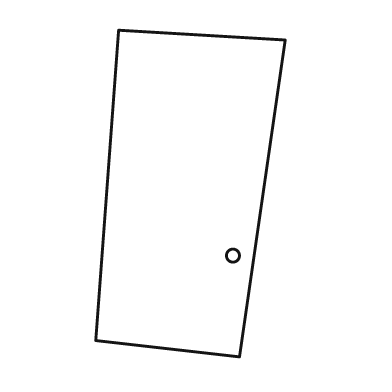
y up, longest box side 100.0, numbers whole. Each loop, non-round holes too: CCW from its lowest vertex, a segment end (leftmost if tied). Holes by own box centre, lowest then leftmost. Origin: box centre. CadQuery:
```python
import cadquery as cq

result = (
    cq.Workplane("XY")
    .moveTo(15.0, -50.0)
    .lineTo(29.0, 47.0)
    .lineTo(-22.0, 50.0)
    .lineTo(-29.0, -45.0)
    .close()
    .moveTo(13.0, -19.0)
    .circle(2.0)
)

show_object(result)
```